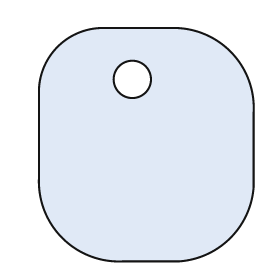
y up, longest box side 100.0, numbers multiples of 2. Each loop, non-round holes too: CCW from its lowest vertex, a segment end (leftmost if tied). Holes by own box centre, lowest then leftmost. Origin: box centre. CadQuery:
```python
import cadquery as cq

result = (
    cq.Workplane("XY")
    .moveTo(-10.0, -50.0)
    .lineTo(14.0, -50.0)
    .threePointArc((36.0, -40.0), (46.0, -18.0))
    .lineTo(46.0, 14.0)
    .threePointArc((36.0, 40.0), (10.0, 50.0))
    .lineTo(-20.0, 50.0)
    .threePointArc((-38.0, 42.0), (-46.0, 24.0))
    .lineTo(-46.0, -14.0)
    .threePointArc((-36.0, -40.0), (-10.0, -50.0))
    .close()
    .moveTo(-6.0, 28.0)
    .circle(8.0)
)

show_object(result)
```